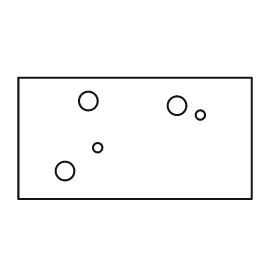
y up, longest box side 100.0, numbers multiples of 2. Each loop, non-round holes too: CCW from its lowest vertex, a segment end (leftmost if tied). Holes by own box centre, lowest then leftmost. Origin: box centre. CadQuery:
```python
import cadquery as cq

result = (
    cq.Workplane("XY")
    .moveTo(-50.0, -26.0)
    .lineTo(50.0, -26.0)
    .lineTo(50.0, 26.0)
    .lineTo(-50.0, 26.0)
    .close()
    .moveTo(-30.0, -14.0)
    .circle(4.0)
    .moveTo(-16.0, -4.0)
    .circle(2.0)
    .moveTo(28.0, 10.0)
    .circle(2.0)
    .moveTo(18.0, 14.0)
    .circle(4.0)
    .moveTo(-20.0, 16.0)
    .circle(4.0)
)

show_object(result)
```